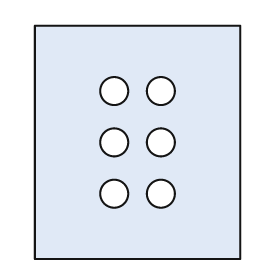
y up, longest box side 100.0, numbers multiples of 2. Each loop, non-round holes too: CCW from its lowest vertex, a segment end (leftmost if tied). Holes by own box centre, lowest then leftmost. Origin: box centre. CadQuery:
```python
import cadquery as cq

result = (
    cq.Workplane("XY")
    .moveTo(-44.0, -50.0)
    .lineTo(44.0, -50.0)
    .lineTo(44.0, 50.0)
    .lineTo(-44.0, 50.0)
    .close()
    .moveTo(-10.0, -22.0)
    .circle(6.0)
    .moveTo(10.0, -22.0)
    .circle(6.0)
    .moveTo(-10.0, 0.0)
    .circle(6.0)
    .moveTo(10.0, 0.0)
    .circle(6.0)
    .moveTo(-10.0, 22.0)
    .circle(6.0)
    .moveTo(10.0, 22.0)
    .circle(6.0)
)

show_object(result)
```